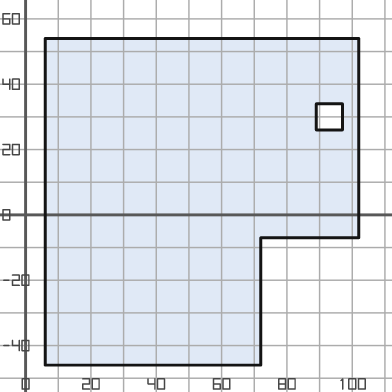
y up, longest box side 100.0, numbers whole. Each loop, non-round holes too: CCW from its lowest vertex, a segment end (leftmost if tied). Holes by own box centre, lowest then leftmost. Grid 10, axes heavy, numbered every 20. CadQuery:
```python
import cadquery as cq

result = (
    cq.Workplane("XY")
    .moveTo(6.0, -46.0)
    .lineTo(72.0, -46.0)
    .lineTo(72.0, -7.0)
    .lineTo(102.0, -7.0)
    .lineTo(102.0, 54.0)
    .lineTo(6.0, 54.0)
    .close()
    .moveTo(89.0, 26.0)
    .lineTo(97.0, 26.0)
    .lineTo(97.0, 34.0)
    .lineTo(89.0, 34.0)
    .close()
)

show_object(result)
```